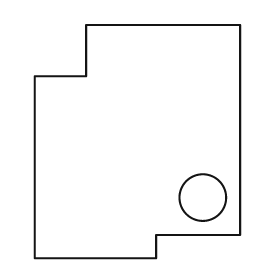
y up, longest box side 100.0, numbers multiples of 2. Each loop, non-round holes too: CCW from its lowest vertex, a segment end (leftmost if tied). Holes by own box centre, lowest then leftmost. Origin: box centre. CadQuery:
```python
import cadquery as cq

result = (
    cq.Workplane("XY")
    .moveTo(-44.0, -50.0)
    .lineTo(8.0, -50.0)
    .lineTo(8.0, -40.0)
    .lineTo(44.0, -40.0)
    .lineTo(44.0, 50.0)
    .lineTo(-22.0, 50.0)
    .lineTo(-22.0, 28.0)
    .lineTo(-44.0, 28.0)
    .close()
    .moveTo(28.0, -24.0)
    .circle(10.0)
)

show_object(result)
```